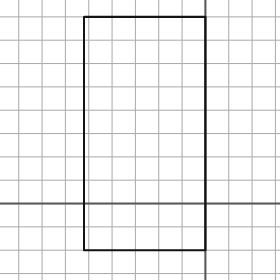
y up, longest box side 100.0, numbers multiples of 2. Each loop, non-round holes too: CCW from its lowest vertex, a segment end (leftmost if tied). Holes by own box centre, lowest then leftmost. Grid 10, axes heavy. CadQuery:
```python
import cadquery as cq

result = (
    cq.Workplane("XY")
    .moveTo(-52.0, -20.0)
    .lineTo(0.0, -20.0)
    .lineTo(0.0, 80.0)
    .lineTo(-52.0, 80.0)
    .close()
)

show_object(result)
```